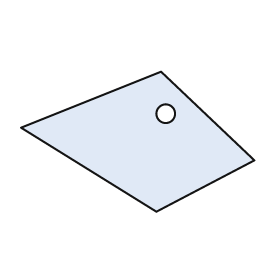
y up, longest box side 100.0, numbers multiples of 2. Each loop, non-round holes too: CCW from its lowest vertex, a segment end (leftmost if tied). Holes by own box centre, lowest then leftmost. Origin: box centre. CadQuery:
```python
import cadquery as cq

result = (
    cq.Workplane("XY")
    .moveTo(8.0, -30.0)
    .lineTo(50.0, -8.0)
    .lineTo(10.0, 30.0)
    .lineTo(-50.0, 6.0)
    .close()
    .moveTo(12.0, 12.0)
    .circle(4.0)
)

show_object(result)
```